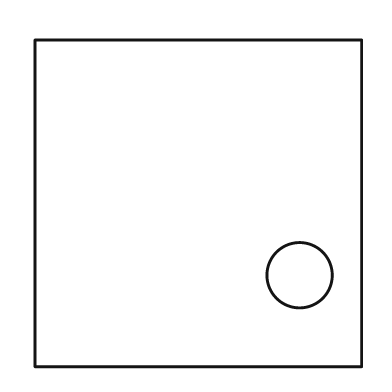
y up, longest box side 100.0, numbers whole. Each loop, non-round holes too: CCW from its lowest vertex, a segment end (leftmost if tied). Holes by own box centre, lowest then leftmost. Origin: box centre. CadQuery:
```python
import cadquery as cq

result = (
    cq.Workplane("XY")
    .moveTo(-50.0, -50.0)
    .lineTo(50.0, -50.0)
    .lineTo(50.0, 50.0)
    .lineTo(-50.0, 50.0)
    .close()
    .moveTo(31.0, -22.0)
    .circle(10.0)
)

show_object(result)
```